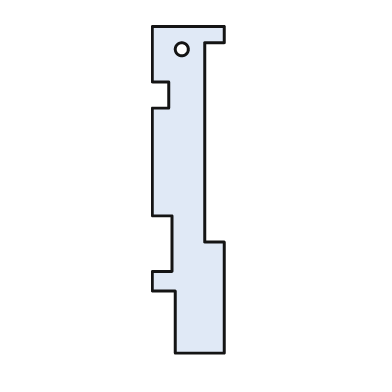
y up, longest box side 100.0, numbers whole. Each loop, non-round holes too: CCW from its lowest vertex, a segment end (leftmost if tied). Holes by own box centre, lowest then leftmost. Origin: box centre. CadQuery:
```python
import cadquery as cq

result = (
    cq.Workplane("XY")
    .moveTo(-4.0, -50.0)
    .lineTo(11.0, -50.0)
    .lineTo(11.0, -16.0)
    .lineTo(5.0, -16.0)
    .lineTo(5.0, 45.0)
    .lineTo(11.0, 45.0)
    .lineTo(11.0, 50.0)
    .lineTo(-11.0, 50.0)
    .lineTo(-11.0, 33.0)
    .lineTo(-6.0, 33.0)
    .lineTo(-6.0, 25.0)
    .lineTo(-11.0, 25.0)
    .lineTo(-11.0, -8.0)
    .lineTo(-5.0, -8.0)
    .lineTo(-5.0, -25.0)
    .lineTo(-11.0, -25.0)
    .lineTo(-11.0, -31.0)
    .lineTo(-4.0, -31.0)
    .close()
    .moveTo(-2.0, 43.0)
    .circle(2.0)
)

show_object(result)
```